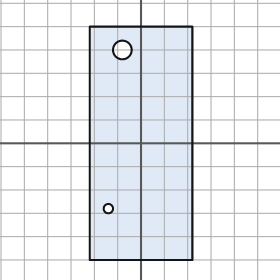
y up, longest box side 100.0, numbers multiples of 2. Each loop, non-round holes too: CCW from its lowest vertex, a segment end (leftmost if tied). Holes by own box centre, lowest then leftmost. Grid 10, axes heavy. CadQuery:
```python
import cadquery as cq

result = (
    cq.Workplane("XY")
    .moveTo(-22.0, -50.0)
    .lineTo(22.0, -50.0)
    .lineTo(22.0, 50.0)
    .lineTo(-22.0, 50.0)
    .close()
    .moveTo(-14.0, -28.0)
    .circle(2.0)
    .moveTo(-8.0, 40.0)
    .circle(4.0)
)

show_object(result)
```